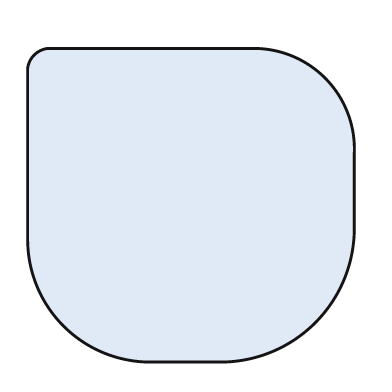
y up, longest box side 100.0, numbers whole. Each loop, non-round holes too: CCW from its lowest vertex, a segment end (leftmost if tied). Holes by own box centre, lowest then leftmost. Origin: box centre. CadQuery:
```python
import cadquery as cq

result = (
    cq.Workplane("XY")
    .moveTo(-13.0, -48.0)
    .lineTo(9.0, -48.0)
    .threePointArc((38.0, -36.0), (50.0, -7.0))
    .lineTo(50.0, 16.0)
    .threePointArc((41.0, 39.0), (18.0, 48.0))
    .lineTo(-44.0, 48.0)
    .threePointArc((-48.0, 46.0), (-50.0, 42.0))
    .lineTo(-50.0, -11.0)
    .threePointArc((-39.0, -37.0), (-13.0, -48.0))
    .close()
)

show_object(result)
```